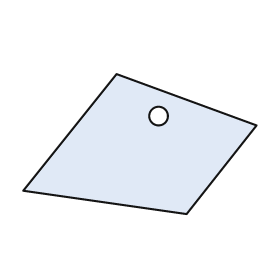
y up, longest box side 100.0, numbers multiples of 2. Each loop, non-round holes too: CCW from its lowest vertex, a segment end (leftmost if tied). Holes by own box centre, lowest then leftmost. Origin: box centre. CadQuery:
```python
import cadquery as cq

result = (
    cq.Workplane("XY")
    .moveTo(20.0, -30.0)
    .lineTo(50.0, 8.0)
    .lineTo(-10.0, 30.0)
    .lineTo(-50.0, -20.0)
    .close()
    .moveTo(8.0, 12.0)
    .circle(4.0)
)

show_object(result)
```